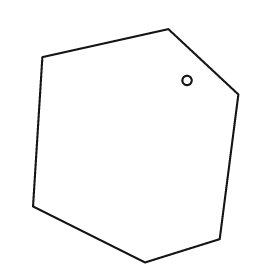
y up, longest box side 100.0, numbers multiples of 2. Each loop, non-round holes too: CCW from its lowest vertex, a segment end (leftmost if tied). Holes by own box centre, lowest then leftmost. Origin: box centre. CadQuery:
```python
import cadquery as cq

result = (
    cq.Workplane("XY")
    .moveTo(4.0, -50.0)
    .lineTo(36.0, -40.0)
    .lineTo(44.0, 22.0)
    .lineTo(14.0, 50.0)
    .lineTo(-40.0, 38.0)
    .lineTo(-44.0, -26.0)
    .close()
    .moveTo(22.0, 28.0)
    .circle(2.0)
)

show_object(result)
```